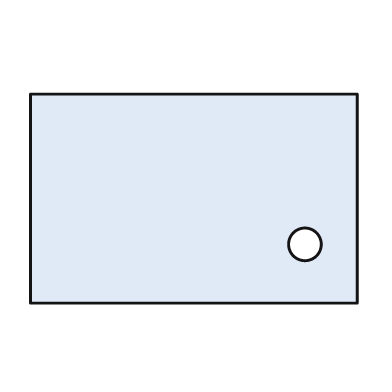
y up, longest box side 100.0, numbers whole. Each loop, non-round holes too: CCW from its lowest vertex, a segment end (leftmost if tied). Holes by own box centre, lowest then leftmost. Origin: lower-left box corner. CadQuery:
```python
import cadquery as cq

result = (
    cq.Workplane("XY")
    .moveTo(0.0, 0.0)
    .lineTo(100.0, 0.0)
    .lineTo(100.0, 64.0)
    .lineTo(0.0, 64.0)
    .close()
    .moveTo(84.0, 18.0)
    .circle(5.0)
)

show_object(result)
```